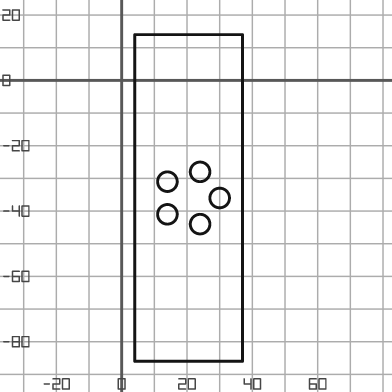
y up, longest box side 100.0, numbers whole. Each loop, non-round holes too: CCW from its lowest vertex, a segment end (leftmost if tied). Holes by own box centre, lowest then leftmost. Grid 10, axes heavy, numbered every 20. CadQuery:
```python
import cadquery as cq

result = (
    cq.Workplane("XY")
    .moveTo(4.0, -86.0)
    .lineTo(37.0, -86.0)
    .lineTo(37.0, 14.0)
    .lineTo(4.0, 14.0)
    .close()
    .moveTo(24.0, -44.0)
    .circle(3.0)
    .moveTo(14.0, -41.0)
    .circle(3.0)
    .moveTo(30.0, -36.0)
    .circle(3.0)
    .moveTo(14.0, -31.0)
    .circle(3.0)
    .moveTo(24.0, -28.0)
    .circle(3.0)
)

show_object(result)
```